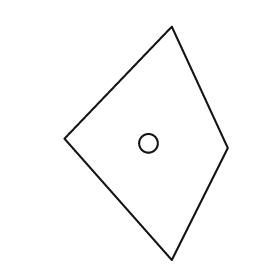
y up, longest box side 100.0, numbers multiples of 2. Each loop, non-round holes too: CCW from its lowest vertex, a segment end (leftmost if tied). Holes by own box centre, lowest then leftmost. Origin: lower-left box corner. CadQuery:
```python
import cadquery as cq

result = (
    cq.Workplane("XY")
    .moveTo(46.0, 0.0)
    .lineTo(70.0, 48.0)
    .lineTo(46.0, 100.0)
    .lineTo(0.0, 52.0)
    .close()
    .moveTo(36.0, 50.0)
    .circle(4.0)
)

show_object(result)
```